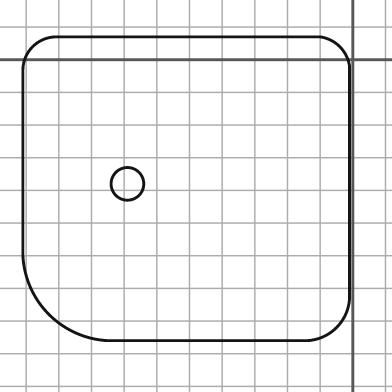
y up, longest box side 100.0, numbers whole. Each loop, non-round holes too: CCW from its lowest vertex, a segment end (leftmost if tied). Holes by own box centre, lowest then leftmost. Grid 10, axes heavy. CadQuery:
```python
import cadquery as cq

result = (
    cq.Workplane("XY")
    .moveTo(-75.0, -86.0)
    .lineTo(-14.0, -86.0)
    .threePointArc((-5.0, -82.0), (-1.0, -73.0))
    .lineTo(-1.0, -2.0)
    .threePointArc((-4.0, 4.0), (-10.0, 7.0))
    .lineTo(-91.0, 7.0)
    .threePointArc((-98.0, 4.0), (-101.0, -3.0))
    .lineTo(-101.0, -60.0)
    .threePointArc((-93.0, -78.0), (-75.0, -86.0))
    .close()
    .moveTo(-69.0, -38.0)
    .circle(5.0)
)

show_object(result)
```